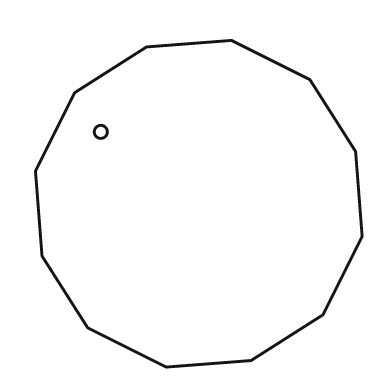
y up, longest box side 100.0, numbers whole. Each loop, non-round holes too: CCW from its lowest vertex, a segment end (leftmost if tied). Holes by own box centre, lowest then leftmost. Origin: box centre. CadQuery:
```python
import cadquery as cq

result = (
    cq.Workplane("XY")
    .moveTo(-10.0, -50.0)
    .lineTo(16.0, -48.0)
    .lineTo(38.0, -34.0)
    .lineTo(50.0, -10.0)
    .lineTo(48.0, 16.0)
    .lineTo(34.0, 38.0)
    .lineTo(10.0, 50.0)
    .lineTo(-16.0, 48.0)
    .lineTo(-38.0, 34.0)
    .lineTo(-50.0, 10.0)
    .lineTo(-48.0, -16.0)
    .lineTo(-34.0, -38.0)
    .close()
    .moveTo(-30.0, 22.0)
    .circle(2.0)
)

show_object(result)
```